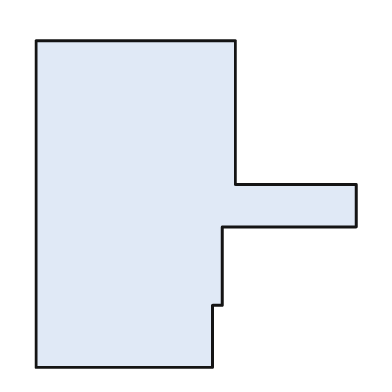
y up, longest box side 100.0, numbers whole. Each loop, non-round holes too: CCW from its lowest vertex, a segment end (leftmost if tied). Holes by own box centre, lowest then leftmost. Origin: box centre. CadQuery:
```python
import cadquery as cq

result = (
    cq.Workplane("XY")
    .moveTo(-49.0, -50.0)
    .lineTo(5.0, -50.0)
    .lineTo(5.0, -31.0)
    .lineTo(8.0, -31.0)
    .lineTo(8.0, -7.0)
    .lineTo(49.0, -7.0)
    .lineTo(49.0, 6.0)
    .lineTo(12.0, 6.0)
    .lineTo(12.0, 50.0)
    .lineTo(-49.0, 50.0)
    .close()
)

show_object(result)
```